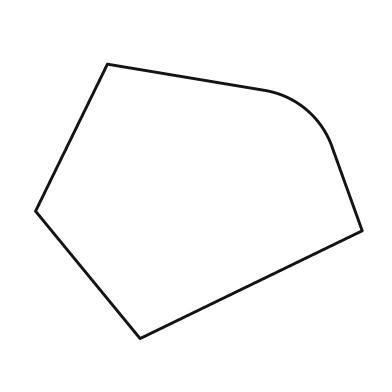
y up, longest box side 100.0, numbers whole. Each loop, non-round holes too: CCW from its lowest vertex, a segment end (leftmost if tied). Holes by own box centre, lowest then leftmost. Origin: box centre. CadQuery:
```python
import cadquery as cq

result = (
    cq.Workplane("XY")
    .moveTo(-18.0, -42.0)
    .lineTo(50.0, -9.0)
    .lineTo(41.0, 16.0)
    .threePointArc((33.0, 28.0), (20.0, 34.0))
    .lineTo(-28.0, 42.0)
    .lineTo(-50.0, -3.0)
    .close()
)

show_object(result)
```